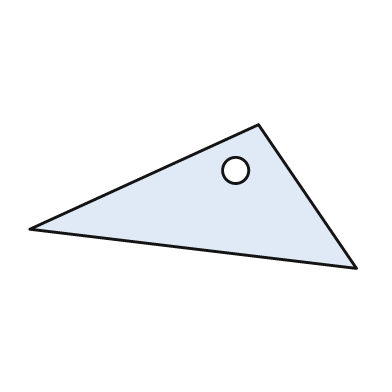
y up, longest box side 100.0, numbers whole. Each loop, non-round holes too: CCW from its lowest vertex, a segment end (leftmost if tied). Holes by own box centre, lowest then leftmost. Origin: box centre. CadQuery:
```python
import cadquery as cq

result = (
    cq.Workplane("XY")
    .moveTo(50.0, -22.0)
    .lineTo(20.0, 22.0)
    .lineTo(-50.0, -10.0)
    .close()
    .moveTo(13.0, 8.0)
    .circle(4.0)
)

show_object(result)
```